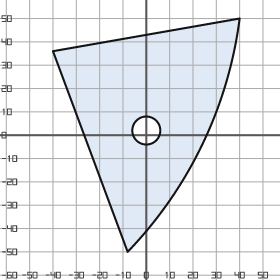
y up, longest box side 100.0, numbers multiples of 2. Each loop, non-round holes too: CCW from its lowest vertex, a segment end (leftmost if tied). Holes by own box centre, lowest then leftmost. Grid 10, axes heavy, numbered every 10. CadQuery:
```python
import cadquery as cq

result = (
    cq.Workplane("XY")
    .moveTo(-8.0, -50.0)
    .threePointArc((24.0, -4.0), (40.0, 50.0))
    .lineTo(-40.0, 36.0)
    .close()
    .moveTo(0.0, 2.0)
    .circle(6.0)
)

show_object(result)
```